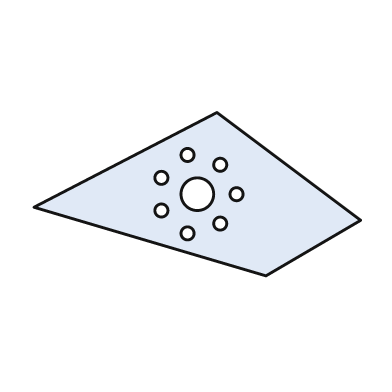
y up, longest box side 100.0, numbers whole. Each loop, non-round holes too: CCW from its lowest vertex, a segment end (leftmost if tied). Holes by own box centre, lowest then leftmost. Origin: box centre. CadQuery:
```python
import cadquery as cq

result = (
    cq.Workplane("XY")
    .moveTo(21.0, -25.0)
    .lineTo(50.0, -8.0)
    .lineTo(6.0, 25.0)
    .lineTo(-50.0, -4.0)
    .close()
    .moveTo(-3.0, -12.0)
    .circle(2.0)
    .moveTo(7.0, -9.0)
    .circle(2.0)
    .moveTo(-11.0, -5.0)
    .circle(2.0)
    .moveTo(0.0, 0.0)
    .circle(5.0)
    .moveTo(12.0, 0.0)
    .circle(2.0)
    .moveTo(-11.0, 5.0)
    .circle(2.0)
    .moveTo(7.0, 9.0)
    .circle(2.0)
    .moveTo(-3.0, 12.0)
    .circle(2.0)
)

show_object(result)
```